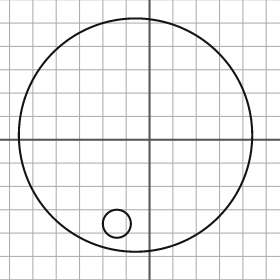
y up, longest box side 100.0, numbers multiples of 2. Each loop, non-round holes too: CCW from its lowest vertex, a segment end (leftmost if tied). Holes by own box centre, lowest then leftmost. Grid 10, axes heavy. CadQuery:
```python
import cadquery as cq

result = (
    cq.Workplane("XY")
    .moveTo(-6.0, 2.0)
    .circle(50.0)
    .moveTo(-14.0, -36.0)
    .circle(6.0)
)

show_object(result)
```